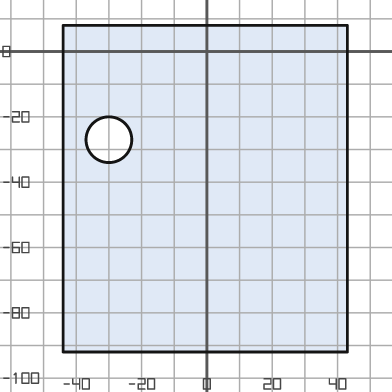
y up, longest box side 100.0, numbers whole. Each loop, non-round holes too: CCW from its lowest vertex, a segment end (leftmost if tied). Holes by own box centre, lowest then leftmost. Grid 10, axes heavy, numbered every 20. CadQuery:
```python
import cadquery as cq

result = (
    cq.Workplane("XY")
    .moveTo(-44.0, -92.0)
    .lineTo(43.0, -92.0)
    .lineTo(43.0, 8.0)
    .lineTo(-44.0, 8.0)
    .close()
    .moveTo(-30.0, -27.0)
    .circle(7.0)
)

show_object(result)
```